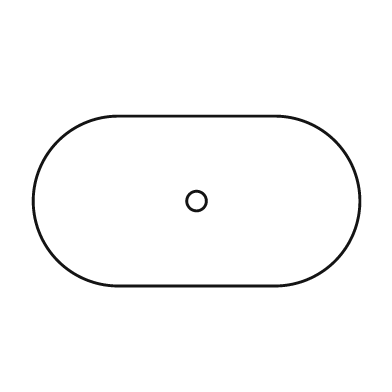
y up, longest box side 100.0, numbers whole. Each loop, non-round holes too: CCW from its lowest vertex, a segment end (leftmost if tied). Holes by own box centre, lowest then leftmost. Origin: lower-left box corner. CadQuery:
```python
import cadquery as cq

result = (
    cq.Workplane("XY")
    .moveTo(26.0, 0.0)
    .lineTo(74.0, 0.0)
    .threePointArc((100.0, 26.0), (74.0, 52.0))
    .lineTo(26.0, 52.0)
    .threePointArc((0.0, 26.0), (26.0, 0.0))
    .close()
    .moveTo(50.0, 26.0)
    .circle(3.0)
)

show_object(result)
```